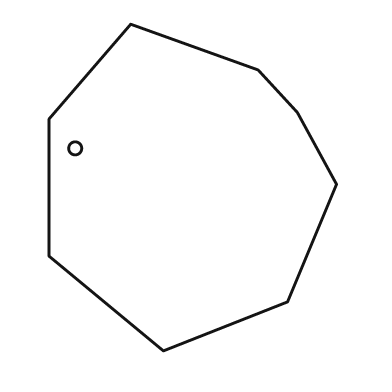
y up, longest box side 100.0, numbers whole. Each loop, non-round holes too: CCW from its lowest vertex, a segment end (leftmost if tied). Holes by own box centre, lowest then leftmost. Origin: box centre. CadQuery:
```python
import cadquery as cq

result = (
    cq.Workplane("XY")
    .moveTo(-9.0, -50.0)
    .lineTo(29.0, -35.0)
    .lineTo(44.0, 1.0)
    .lineTo(32.0, 23.0)
    .lineTo(20.0, 36.0)
    .lineTo(-19.0, 50.0)
    .lineTo(-44.0, 21.0)
    .lineTo(-44.0, -21.0)
    .close()
    .moveTo(-36.0, 12.0)
    .circle(2.0)
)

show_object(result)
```